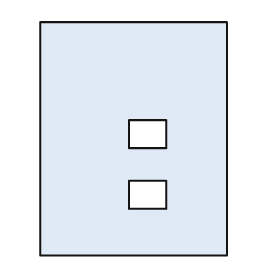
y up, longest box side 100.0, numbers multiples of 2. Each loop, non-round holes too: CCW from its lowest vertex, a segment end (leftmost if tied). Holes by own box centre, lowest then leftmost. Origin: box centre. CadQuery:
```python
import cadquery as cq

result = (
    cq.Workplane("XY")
    .moveTo(-40.0, -50.0)
    .lineTo(40.0, -50.0)
    .lineTo(40.0, 50.0)
    .lineTo(-40.0, 50.0)
    .close()
    .moveTo(-2.0, -30.0)
    .lineTo(14.0, -30.0)
    .lineTo(14.0, -18.0)
    .lineTo(-2.0, -18.0)
    .close()
    .moveTo(-2.0, -4.0)
    .lineTo(14.0, -4.0)
    .lineTo(14.0, 8.0)
    .lineTo(-2.0, 8.0)
    .close()
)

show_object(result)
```